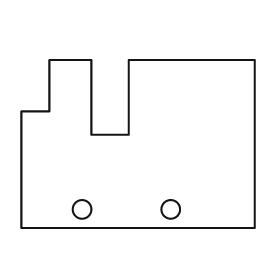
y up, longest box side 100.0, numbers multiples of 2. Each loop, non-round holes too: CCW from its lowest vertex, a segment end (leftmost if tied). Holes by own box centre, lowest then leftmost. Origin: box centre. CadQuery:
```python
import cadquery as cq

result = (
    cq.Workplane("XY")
    .moveTo(-50.0, -36.0)
    .lineTo(50.0, -36.0)
    .lineTo(50.0, 36.0)
    .lineTo(-4.0, 36.0)
    .lineTo(-4.0, 4.0)
    .lineTo(-20.0, 4.0)
    .lineTo(-20.0, 36.0)
    .lineTo(-38.0, 36.0)
    .lineTo(-38.0, 14.0)
    .lineTo(-50.0, 14.0)
    .close()
    .moveTo(-24.0, -28.0)
    .circle(4.0)
    .moveTo(14.0, -28.0)
    .circle(4.0)
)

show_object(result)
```